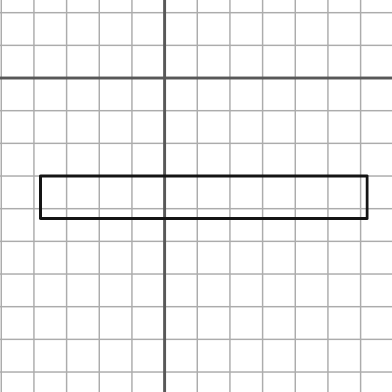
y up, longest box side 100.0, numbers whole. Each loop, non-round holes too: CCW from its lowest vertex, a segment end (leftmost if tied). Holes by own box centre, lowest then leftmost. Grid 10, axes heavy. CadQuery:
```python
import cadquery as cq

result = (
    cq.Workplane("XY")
    .moveTo(-38.0, -43.0)
    .lineTo(62.0, -43.0)
    .lineTo(62.0, -30.0)
    .lineTo(-38.0, -30.0)
    .close()
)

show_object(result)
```